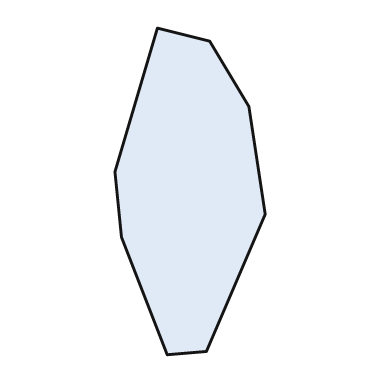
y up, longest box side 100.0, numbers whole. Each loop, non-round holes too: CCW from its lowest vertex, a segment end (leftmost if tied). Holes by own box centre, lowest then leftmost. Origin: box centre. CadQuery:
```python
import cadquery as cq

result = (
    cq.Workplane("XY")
    .moveTo(-7.0, -50.0)
    .lineTo(5.0, -49.0)
    .lineTo(23.0, -7.0)
    .lineTo(18.0, 26.0)
    .lineTo(6.0, 46.0)
    .lineTo(-10.0, 50.0)
    .lineTo(-23.0, 6.0)
    .lineTo(-21.0, -14.0)
    .close()
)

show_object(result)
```